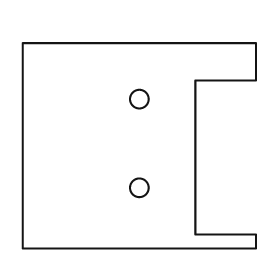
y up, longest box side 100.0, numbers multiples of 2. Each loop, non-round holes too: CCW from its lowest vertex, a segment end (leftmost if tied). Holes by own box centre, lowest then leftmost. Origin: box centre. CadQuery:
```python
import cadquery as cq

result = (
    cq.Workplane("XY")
    .moveTo(-50.0, -44.0)
    .lineTo(50.0, -44.0)
    .lineTo(50.0, -38.0)
    .lineTo(24.0, -38.0)
    .lineTo(24.0, 28.0)
    .lineTo(50.0, 28.0)
    .lineTo(50.0, 44.0)
    .lineTo(-50.0, 44.0)
    .close()
    .moveTo(0.0, -18.0)
    .circle(4.0)
    .moveTo(0.0, 20.0)
    .circle(4.0)
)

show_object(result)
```